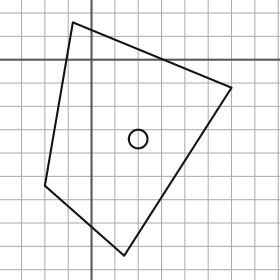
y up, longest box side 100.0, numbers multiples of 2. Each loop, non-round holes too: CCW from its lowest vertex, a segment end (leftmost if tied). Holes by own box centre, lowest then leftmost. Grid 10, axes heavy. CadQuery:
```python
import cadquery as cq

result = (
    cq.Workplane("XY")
    .moveTo(14.0, -84.0)
    .lineTo(60.0, -12.0)
    .lineTo(-8.0, 16.0)
    .lineTo(-20.0, -54.0)
    .close()
    .moveTo(20.0, -34.0)
    .circle(4.0)
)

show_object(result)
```